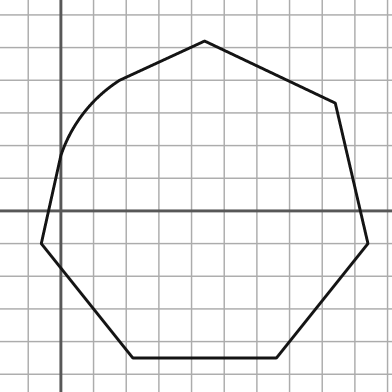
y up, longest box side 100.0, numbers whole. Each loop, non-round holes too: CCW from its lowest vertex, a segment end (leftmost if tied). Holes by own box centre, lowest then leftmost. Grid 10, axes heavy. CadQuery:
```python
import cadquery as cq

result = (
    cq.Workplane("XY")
    .moveTo(22.0, -45.0)
    .lineTo(66.0, -45.0)
    .lineTo(94.0, -10.0)
    .lineTo(84.0, 33.0)
    .lineTo(44.0, 52.0)
    .lineTo(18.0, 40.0)
    .threePointArc((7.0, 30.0), (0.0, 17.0))
    .lineTo(-6.0, -10.0)
    .close()
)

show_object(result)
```